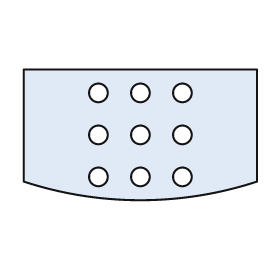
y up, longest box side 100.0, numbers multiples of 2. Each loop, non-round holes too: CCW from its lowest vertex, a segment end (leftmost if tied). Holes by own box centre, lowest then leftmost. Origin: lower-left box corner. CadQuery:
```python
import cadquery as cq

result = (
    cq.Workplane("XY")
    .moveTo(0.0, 8.0)
    .threePointArc((50.0, 0.0), (100.0, 8.0))
    .lineTo(100.0, 56.0)
    .lineTo(0.0, 56.0)
    .close()
    .moveTo(32.0, 10.0)
    .circle(4.0)
    .moveTo(50.0, 10.0)
    .circle(4.0)
    .moveTo(68.0, 10.0)
    .circle(4.0)
    .moveTo(32.0, 28.0)
    .circle(4.0)
    .moveTo(50.0, 28.0)
    .circle(4.0)
    .moveTo(68.0, 28.0)
    .circle(4.0)
    .moveTo(32.0, 46.0)
    .circle(4.0)
    .moveTo(50.0, 46.0)
    .circle(4.0)
    .moveTo(68.0, 46.0)
    .circle(4.0)
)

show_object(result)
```